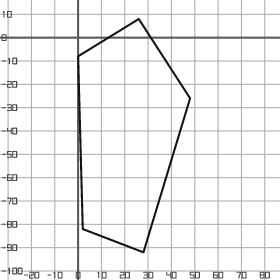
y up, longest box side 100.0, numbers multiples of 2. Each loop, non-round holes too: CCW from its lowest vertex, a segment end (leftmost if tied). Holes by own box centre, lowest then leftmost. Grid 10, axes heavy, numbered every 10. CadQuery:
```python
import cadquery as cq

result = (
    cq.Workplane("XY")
    .moveTo(28.0, -92.0)
    .lineTo(48.0, -26.0)
    .lineTo(26.0, 8.0)
    .lineTo(0.0, -8.0)
    .lineTo(2.0, -82.0)
    .close()
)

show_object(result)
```